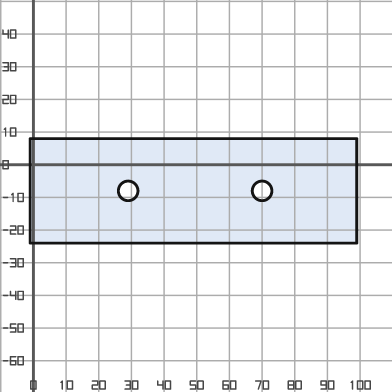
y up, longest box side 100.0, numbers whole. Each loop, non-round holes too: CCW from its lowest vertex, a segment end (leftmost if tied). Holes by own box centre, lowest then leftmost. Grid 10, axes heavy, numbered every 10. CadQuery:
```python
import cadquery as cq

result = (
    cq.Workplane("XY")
    .moveTo(-1.0, -24.0)
    .lineTo(99.0, -24.0)
    .lineTo(99.0, 8.0)
    .lineTo(-1.0, 8.0)
    .close()
    .moveTo(29.0, -8.0)
    .circle(3.0)
    .moveTo(70.0, -8.0)
    .circle(3.0)
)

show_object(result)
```